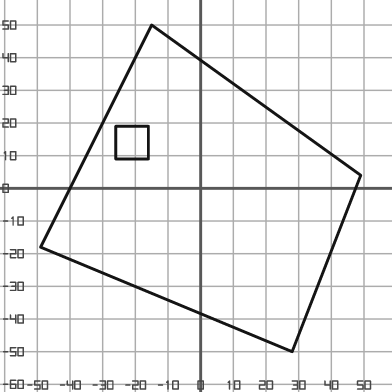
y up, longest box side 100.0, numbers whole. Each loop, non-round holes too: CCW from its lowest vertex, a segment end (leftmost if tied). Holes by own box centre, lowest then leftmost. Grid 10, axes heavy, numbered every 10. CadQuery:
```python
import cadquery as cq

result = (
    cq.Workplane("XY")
    .moveTo(28.0, -50.0)
    .lineTo(49.0, 4.0)
    .lineTo(-15.0, 50.0)
    .lineTo(-49.0, -18.0)
    .close()
    .moveTo(-26.0, 9.0)
    .lineTo(-16.0, 9.0)
    .lineTo(-16.0, 19.0)
    .lineTo(-26.0, 19.0)
    .close()
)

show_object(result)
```